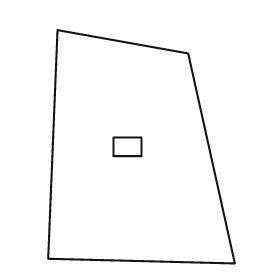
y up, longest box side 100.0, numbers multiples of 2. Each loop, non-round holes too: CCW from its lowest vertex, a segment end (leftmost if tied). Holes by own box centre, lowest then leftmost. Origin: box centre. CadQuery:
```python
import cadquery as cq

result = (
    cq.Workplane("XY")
    .moveTo(40.0, -50.0)
    .lineTo(20.0, 40.0)
    .lineTo(-36.0, 50.0)
    .lineTo(-40.0, -48.0)
    .close()
    .moveTo(-12.0, -4.0)
    .lineTo(0.0, -4.0)
    .lineTo(0.0, 4.0)
    .lineTo(-12.0, 4.0)
    .close()
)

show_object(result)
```